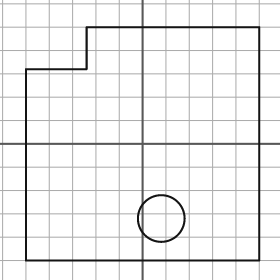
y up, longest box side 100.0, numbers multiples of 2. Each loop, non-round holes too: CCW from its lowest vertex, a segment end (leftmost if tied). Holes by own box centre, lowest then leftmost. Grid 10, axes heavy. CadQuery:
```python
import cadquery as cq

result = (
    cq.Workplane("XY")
    .moveTo(-50.0, -50.0)
    .lineTo(50.0, -50.0)
    .lineTo(50.0, 50.0)
    .lineTo(-24.0, 50.0)
    .lineTo(-24.0, 32.0)
    .lineTo(-50.0, 32.0)
    .close()
    .moveTo(8.0, -32.0)
    .circle(10.0)
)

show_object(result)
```